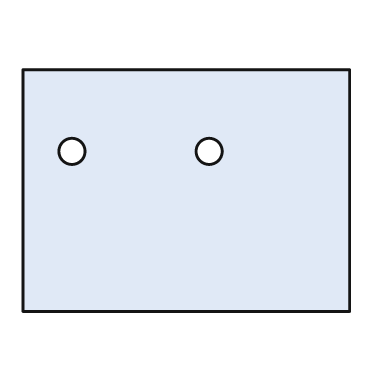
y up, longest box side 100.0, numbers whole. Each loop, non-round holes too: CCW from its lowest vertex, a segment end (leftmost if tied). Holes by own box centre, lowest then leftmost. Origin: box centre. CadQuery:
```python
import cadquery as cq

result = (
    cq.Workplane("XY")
    .moveTo(-50.0, -37.0)
    .lineTo(50.0, -37.0)
    .lineTo(50.0, 37.0)
    .lineTo(-50.0, 37.0)
    .close()
    .moveTo(-35.0, 12.0)
    .circle(4.0)
    .moveTo(7.0, 12.0)
    .circle(4.0)
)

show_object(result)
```